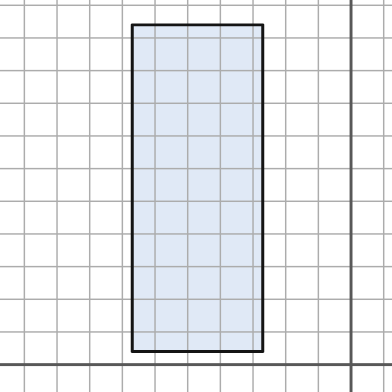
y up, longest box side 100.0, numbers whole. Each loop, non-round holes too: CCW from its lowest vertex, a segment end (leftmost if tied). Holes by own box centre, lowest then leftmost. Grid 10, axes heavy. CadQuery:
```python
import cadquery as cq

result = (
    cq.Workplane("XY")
    .moveTo(-67.0, 4.0)
    .lineTo(-27.0, 4.0)
    .lineTo(-27.0, 104.0)
    .lineTo(-67.0, 104.0)
    .close()
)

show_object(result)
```